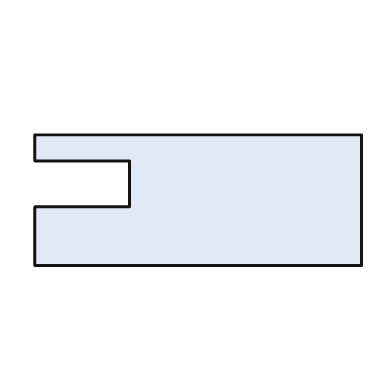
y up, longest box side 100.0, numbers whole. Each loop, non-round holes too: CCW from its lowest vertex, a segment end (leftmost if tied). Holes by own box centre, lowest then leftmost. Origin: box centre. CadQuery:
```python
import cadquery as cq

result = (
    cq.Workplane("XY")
    .moveTo(-50.0, -20.0)
    .lineTo(50.0, -20.0)
    .lineTo(50.0, 20.0)
    .lineTo(-50.0, 20.0)
    .lineTo(-50.0, 12.0)
    .lineTo(-21.0, 12.0)
    .lineTo(-21.0, -2.0)
    .lineTo(-50.0, -2.0)
    .close()
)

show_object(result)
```